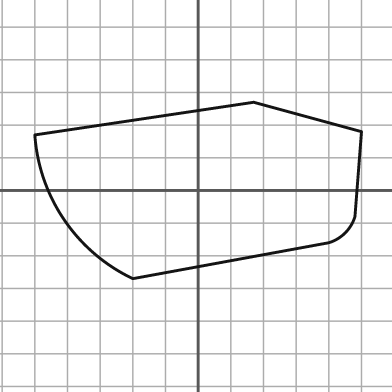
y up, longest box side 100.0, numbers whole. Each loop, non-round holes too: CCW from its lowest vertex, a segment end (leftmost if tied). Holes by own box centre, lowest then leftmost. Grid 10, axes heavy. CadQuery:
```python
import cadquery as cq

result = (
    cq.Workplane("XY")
    .moveTo(-20.0, -27.0)
    .lineTo(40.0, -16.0)
    .threePointArc((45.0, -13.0), (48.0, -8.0))
    .lineTo(50.0, 18.0)
    .lineTo(17.0, 27.0)
    .lineTo(-50.0, 17.0)
    .threePointArc((-41.0, -9.0), (-20.0, -27.0))
    .close()
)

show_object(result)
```